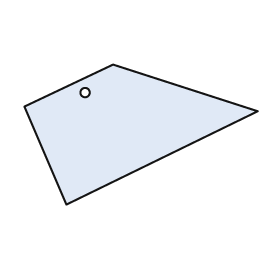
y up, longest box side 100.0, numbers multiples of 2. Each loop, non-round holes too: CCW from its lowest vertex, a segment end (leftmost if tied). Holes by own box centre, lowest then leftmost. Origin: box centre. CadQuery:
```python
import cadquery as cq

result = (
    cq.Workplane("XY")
    .moveTo(-32.0, -30.0)
    .lineTo(50.0, 10.0)
    .lineTo(-12.0, 30.0)
    .lineTo(-50.0, 12.0)
    .close()
    .moveTo(-24.0, 18.0)
    .circle(2.0)
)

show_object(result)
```